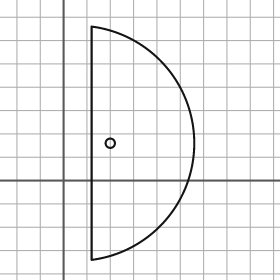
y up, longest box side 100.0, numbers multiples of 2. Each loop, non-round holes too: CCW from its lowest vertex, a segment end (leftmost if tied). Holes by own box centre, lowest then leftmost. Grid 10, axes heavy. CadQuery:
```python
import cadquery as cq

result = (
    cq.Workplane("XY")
    .moveTo(12.0, -34.0)
    .threePointArc((56.0, 16.0), (12.0, 66.0))
    .close()
    .moveTo(20.0, 16.0)
    .circle(2.0)
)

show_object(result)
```